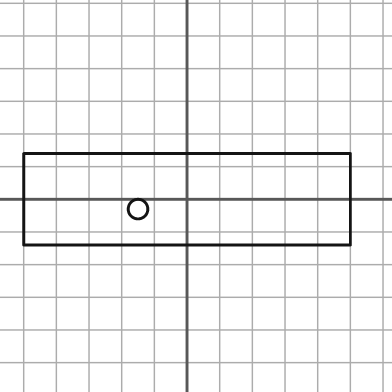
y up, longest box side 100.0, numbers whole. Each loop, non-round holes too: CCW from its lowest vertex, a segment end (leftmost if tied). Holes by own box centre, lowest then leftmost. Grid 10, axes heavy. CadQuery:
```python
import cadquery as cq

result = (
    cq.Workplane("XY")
    .moveTo(-50.0, -14.0)
    .lineTo(50.0, -14.0)
    .lineTo(50.0, 14.0)
    .lineTo(-50.0, 14.0)
    .close()
    .moveTo(-15.0, -3.0)
    .circle(3.0)
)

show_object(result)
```